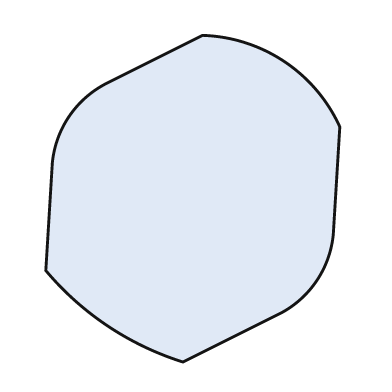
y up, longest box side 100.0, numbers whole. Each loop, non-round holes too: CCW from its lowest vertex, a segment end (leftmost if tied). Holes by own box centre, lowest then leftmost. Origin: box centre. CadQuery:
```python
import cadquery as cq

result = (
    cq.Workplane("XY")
    .moveTo(-3.0, -50.0)
    .lineTo(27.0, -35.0)
    .threePointArc((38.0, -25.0), (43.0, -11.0))
    .lineTo(45.0, 22.0)
    .threePointArc((28.0, 42.0), (3.0, 50.0))
    .lineTo(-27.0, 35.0)
    .threePointArc((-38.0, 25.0), (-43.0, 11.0))
    .lineTo(-45.0, -22.0)
    .threePointArc((-26.0, -39.0), (-3.0, -50.0))
    .close()
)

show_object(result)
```